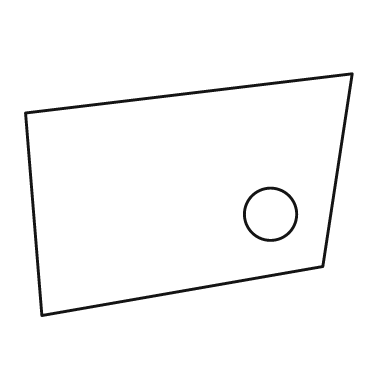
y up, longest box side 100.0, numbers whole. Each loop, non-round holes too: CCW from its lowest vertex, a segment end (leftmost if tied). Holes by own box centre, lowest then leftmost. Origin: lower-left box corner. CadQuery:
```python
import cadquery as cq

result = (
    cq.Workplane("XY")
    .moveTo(5.0, 0.0)
    .lineTo(91.0, 15.0)
    .lineTo(100.0, 74.0)
    .lineTo(0.0, 62.0)
    .close()
    .moveTo(75.0, 31.0)
    .circle(8.0)
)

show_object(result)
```